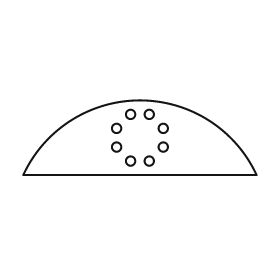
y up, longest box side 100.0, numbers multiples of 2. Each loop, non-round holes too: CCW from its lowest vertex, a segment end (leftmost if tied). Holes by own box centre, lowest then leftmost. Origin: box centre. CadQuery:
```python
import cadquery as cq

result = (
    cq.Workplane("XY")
    .moveTo(-50.0, -16.0)
    .lineTo(50.0, -16.0)
    .threePointArc((0.0, 16.0), (-50.0, -16.0))
    .close()
    .moveTo(-4.0, -10.0)
    .circle(2.0)
    .moveTo(4.0, -10.0)
    .circle(2.0)
    .moveTo(-10.0, -4.0)
    .circle(2.0)
    .moveTo(10.0, -4.0)
    .circle(2.0)
    .moveTo(-10.0, 4.0)
    .circle(2.0)
    .moveTo(10.0, 4.0)
    .circle(2.0)
    .moveTo(-4.0, 10.0)
    .circle(2.0)
    .moveTo(4.0, 10.0)
    .circle(2.0)
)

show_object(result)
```